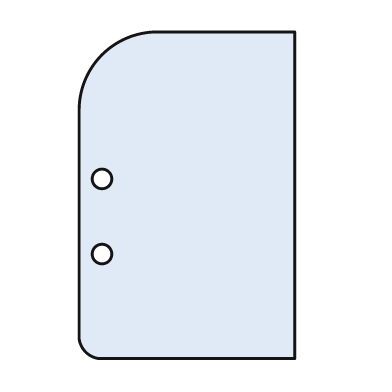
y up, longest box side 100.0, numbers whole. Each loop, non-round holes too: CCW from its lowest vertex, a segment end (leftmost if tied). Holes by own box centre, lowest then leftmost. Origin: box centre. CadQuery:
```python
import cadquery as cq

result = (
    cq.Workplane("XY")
    .moveTo(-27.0, -50.0)
    .lineTo(33.0, -50.0)
    .lineTo(33.0, 50.0)
    .lineTo(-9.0, 50.0)
    .threePointArc((-26.0, 43.0), (-33.0, 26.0))
    .lineTo(-33.0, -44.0)
    .threePointArc((-31.0, -48.0), (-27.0, -50.0))
    .close()
    .moveTo(-26.0, -18.0)
    .circle(3.0)
    .moveTo(-26.0, 5.0)
    .circle(3.0)
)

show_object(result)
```